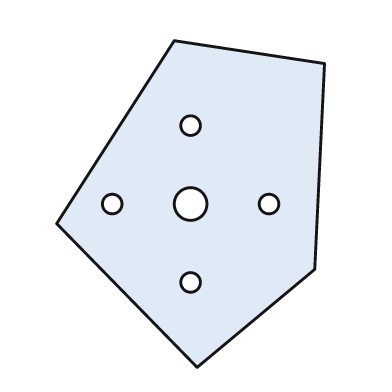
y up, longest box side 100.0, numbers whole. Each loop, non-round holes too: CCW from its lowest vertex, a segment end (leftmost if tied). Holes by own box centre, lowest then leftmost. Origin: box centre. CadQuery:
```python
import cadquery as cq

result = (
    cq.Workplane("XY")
    .moveTo(2.0, -50.0)
    .lineTo(38.0, -20.0)
    .lineTo(41.0, 43.0)
    .lineTo(-5.0, 50.0)
    .lineTo(-41.0, -6.0)
    .close()
    .moveTo(0.0, -24.0)
    .circle(3.0)
    .moveTo(-24.0, 0.0)
    .circle(3.0)
    .moveTo(0.0, 0.0)
    .circle(5.0)
    .moveTo(24.0, 0.0)
    .circle(3.0)
    .moveTo(0.0, 24.0)
    .circle(3.0)
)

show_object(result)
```